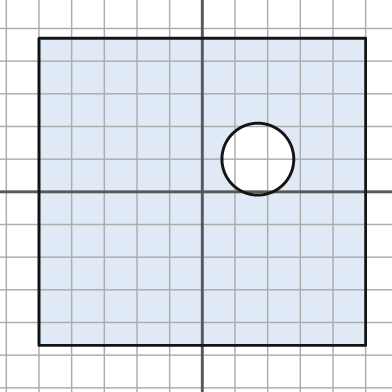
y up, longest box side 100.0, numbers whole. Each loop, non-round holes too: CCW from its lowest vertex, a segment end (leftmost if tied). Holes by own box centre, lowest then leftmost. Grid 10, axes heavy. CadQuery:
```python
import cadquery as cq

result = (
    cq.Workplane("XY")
    .moveTo(-50.0, -47.0)
    .lineTo(50.0, -47.0)
    .lineTo(50.0, 47.0)
    .lineTo(-50.0, 47.0)
    .close()
    .moveTo(17.0, 10.0)
    .circle(11.0)
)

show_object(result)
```